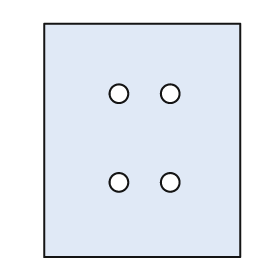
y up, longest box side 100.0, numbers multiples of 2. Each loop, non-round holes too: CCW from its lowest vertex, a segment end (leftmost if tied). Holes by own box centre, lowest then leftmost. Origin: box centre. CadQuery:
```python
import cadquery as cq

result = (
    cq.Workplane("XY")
    .moveTo(-42.0, -50.0)
    .lineTo(42.0, -50.0)
    .lineTo(42.0, 50.0)
    .lineTo(-42.0, 50.0)
    .close()
    .moveTo(-10.0, -18.0)
    .circle(4.0)
    .moveTo(12.0, -18.0)
    .circle(4.0)
    .moveTo(-10.0, 20.0)
    .circle(4.0)
    .moveTo(12.0, 20.0)
    .circle(4.0)
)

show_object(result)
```